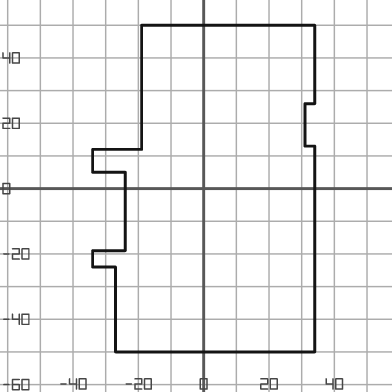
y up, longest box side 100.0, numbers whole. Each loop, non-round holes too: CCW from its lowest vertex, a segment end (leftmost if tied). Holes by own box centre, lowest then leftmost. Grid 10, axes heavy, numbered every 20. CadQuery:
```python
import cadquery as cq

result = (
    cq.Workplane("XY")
    .moveTo(-27.0, -50.0)
    .lineTo(34.0, -50.0)
    .lineTo(34.0, 13.0)
    .lineTo(31.0, 13.0)
    .lineTo(31.0, 26.0)
    .lineTo(34.0, 26.0)
    .lineTo(34.0, 50.0)
    .lineTo(-19.0, 50.0)
    .lineTo(-19.0, 12.0)
    .lineTo(-34.0, 12.0)
    .lineTo(-34.0, 5.0)
    .lineTo(-24.0, 5.0)
    .lineTo(-24.0, -19.0)
    .lineTo(-34.0, -19.0)
    .lineTo(-34.0, -24.0)
    .lineTo(-27.0, -24.0)
    .close()
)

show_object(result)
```